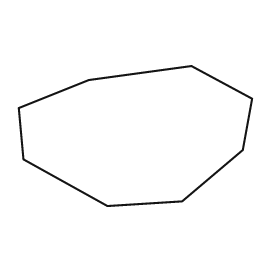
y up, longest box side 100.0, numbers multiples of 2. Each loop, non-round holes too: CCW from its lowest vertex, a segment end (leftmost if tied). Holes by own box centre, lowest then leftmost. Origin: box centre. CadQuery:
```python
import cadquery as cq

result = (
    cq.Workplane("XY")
    .moveTo(-12.0, -30.0)
    .lineTo(20.0, -28.0)
    .lineTo(46.0, -6.0)
    .lineTo(50.0, 16.0)
    .lineTo(24.0, 30.0)
    .lineTo(-20.0, 24.0)
    .lineTo(-50.0, 12.0)
    .lineTo(-48.0, -10.0)
    .close()
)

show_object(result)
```